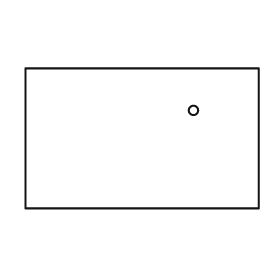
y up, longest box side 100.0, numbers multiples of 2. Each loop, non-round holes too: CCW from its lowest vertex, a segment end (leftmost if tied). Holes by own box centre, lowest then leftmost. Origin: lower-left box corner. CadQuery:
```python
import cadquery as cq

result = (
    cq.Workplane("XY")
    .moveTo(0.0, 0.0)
    .lineTo(100.0, 0.0)
    .lineTo(100.0, 60.0)
    .lineTo(0.0, 60.0)
    .close()
    .moveTo(72.0, 42.0)
    .circle(2.0)
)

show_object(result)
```